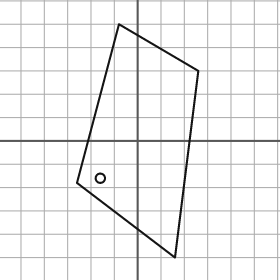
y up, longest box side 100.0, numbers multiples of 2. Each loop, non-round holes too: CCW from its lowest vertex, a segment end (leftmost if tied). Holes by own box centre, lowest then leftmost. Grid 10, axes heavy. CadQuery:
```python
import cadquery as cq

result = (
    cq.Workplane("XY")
    .moveTo(16.0, -50.0)
    .lineTo(26.0, 30.0)
    .lineTo(-8.0, 50.0)
    .lineTo(-26.0, -18.0)
    .close()
    .moveTo(-16.0, -16.0)
    .circle(2.0)
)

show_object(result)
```